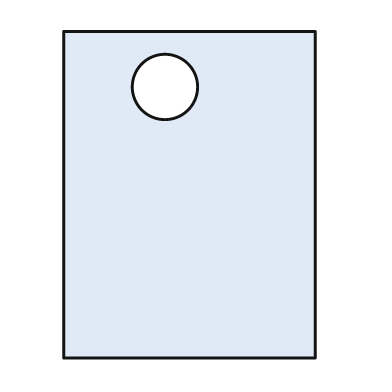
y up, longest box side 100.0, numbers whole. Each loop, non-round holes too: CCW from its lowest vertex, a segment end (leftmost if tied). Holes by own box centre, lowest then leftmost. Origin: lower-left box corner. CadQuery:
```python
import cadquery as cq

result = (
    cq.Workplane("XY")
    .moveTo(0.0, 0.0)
    .lineTo(77.0, 0.0)
    .lineTo(77.0, 100.0)
    .lineTo(0.0, 100.0)
    .close()
    .moveTo(31.0, 83.0)
    .circle(10.0)
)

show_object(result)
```